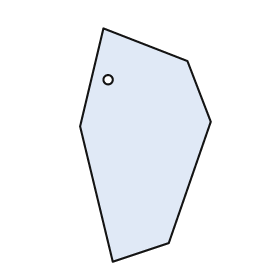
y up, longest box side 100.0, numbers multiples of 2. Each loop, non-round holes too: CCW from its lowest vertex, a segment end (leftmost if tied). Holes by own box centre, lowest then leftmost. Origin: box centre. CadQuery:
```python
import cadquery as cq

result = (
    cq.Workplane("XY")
    .moveTo(-14.0, -50.0)
    .lineTo(10.0, -42.0)
    .lineTo(28.0, 10.0)
    .lineTo(18.0, 36.0)
    .lineTo(-18.0, 50.0)
    .lineTo(-28.0, 8.0)
    .close()
    .moveTo(-16.0, 28.0)
    .circle(2.0)
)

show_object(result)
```